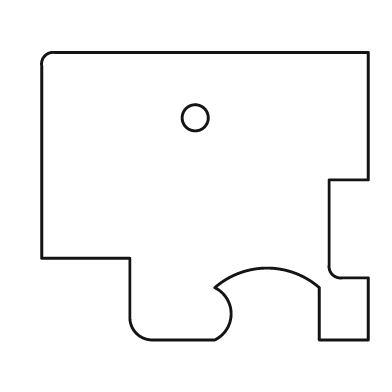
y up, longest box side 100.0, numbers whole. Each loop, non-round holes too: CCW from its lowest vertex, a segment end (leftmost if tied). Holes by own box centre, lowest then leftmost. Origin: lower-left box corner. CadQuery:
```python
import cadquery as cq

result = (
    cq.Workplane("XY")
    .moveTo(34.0, 0.0)
    .lineTo(53.0, 0.0)
    .threePointArc((58.0, 8.0), (53.0, 16.0))
    .threePointArc((69.0, 22.0), (85.0, 16.0))
    .lineTo(85.0, 0.0)
    .lineTo(100.0, 0.0)
    .lineTo(100.0, 19.0)
    .lineTo(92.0, 19.0)
    .threePointArc((89.0, 20.0), (88.0, 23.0))
    .lineTo(88.0, 49.0)
    .lineTo(100.0, 49.0)
    .lineTo(100.0, 88.0)
    .lineTo(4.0, 88.0)
    .threePointArc((1.0, 87.0), (0.0, 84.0))
    .lineTo(0.0, 25.0)
    .lineTo(27.0, 25.0)
    .lineTo(27.0, 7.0)
    .threePointArc((29.0, 2.0), (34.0, 0.0))
    .close()
    .moveTo(47.0, 68.0)
    .circle(4.0)
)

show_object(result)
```